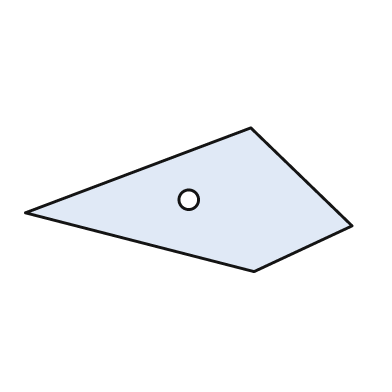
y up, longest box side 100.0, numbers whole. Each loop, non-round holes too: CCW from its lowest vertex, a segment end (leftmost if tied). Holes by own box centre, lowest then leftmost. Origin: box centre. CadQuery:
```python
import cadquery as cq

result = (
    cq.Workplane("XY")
    .moveTo(20.0, -22.0)
    .lineTo(50.0, -8.0)
    .lineTo(19.0, 22.0)
    .lineTo(-50.0, -4.0)
    .close()
    .moveTo(0.0, 0.0)
    .circle(3.0)
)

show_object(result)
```